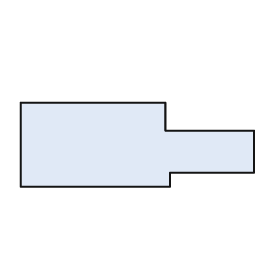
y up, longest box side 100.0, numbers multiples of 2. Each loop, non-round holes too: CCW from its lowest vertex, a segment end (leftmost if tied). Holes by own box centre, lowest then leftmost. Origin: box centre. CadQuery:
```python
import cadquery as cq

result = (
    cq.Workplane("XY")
    .moveTo(-50.0, -18.0)
    .lineTo(14.0, -18.0)
    .lineTo(14.0, -12.0)
    .lineTo(50.0, -12.0)
    .lineTo(50.0, 6.0)
    .lineTo(12.0, 6.0)
    .lineTo(12.0, 18.0)
    .lineTo(-50.0, 18.0)
    .close()
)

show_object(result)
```